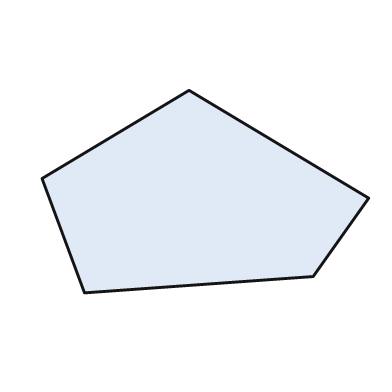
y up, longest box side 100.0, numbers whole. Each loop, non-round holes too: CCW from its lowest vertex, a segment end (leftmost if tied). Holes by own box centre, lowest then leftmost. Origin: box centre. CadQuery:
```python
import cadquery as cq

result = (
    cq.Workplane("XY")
    .moveTo(-37.0, -31.0)
    .lineTo(33.0, -26.0)
    .lineTo(50.0, -2.0)
    .lineTo(-5.0, 31.0)
    .lineTo(-50.0, 4.0)
    .close()
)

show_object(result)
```